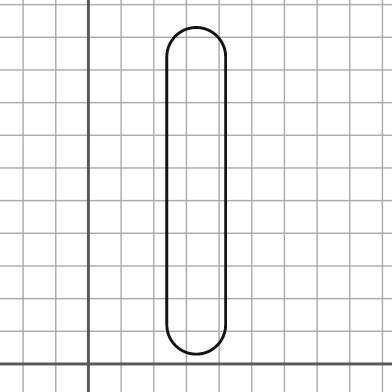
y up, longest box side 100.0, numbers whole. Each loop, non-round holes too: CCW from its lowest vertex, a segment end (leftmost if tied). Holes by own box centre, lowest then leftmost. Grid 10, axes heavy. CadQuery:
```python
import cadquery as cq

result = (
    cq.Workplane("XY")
    .moveTo(24.0, 12.0)
    .threePointArc((33.0, 3.0), (42.0, 12.0))
    .lineTo(42.0, 94.0)
    .threePointArc((33.0, 103.0), (24.0, 94.0))
    .close()
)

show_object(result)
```